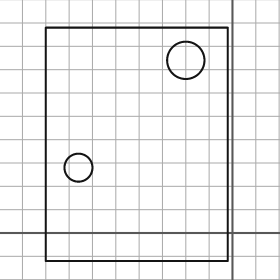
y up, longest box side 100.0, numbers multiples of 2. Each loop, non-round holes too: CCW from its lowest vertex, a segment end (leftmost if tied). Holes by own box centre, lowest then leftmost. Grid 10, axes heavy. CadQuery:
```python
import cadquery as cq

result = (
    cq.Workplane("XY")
    .moveTo(-80.0, -12.0)
    .lineTo(-2.0, -12.0)
    .lineTo(-2.0, 88.0)
    .lineTo(-80.0, 88.0)
    .close()
    .moveTo(-66.0, 28.0)
    .circle(6.0)
    .moveTo(-20.0, 74.0)
    .circle(8.0)
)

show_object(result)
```